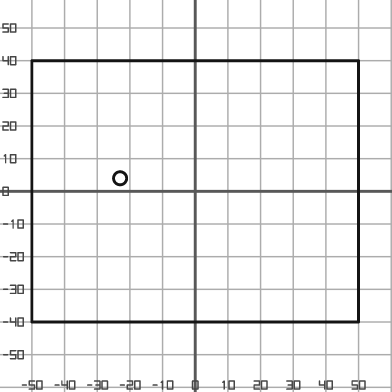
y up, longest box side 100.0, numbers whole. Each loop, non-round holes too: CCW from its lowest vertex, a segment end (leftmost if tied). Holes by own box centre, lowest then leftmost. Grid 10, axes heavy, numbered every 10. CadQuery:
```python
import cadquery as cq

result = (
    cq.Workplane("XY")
    .moveTo(-50.0, -40.0)
    .lineTo(50.0, -40.0)
    .lineTo(50.0, 40.0)
    .lineTo(-50.0, 40.0)
    .close()
    .moveTo(-23.0, 4.0)
    .circle(2.0)
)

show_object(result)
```